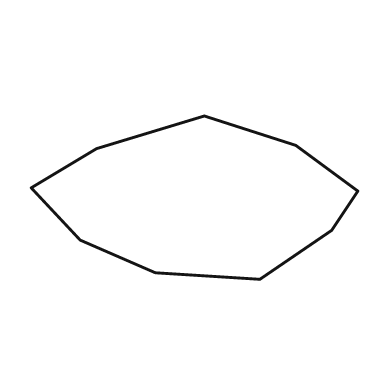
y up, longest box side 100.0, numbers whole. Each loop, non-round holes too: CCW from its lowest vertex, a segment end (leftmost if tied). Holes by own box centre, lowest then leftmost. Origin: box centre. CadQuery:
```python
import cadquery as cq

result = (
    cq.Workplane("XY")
    .moveTo(20.0, -25.0)
    .lineTo(42.0, -10.0)
    .lineTo(50.0, 2.0)
    .lineTo(31.0, 16.0)
    .lineTo(3.0, 25.0)
    .lineTo(-30.0, 15.0)
    .lineTo(-50.0, 3.0)
    .lineTo(-35.0, -13.0)
    .lineTo(-12.0, -23.0)
    .close()
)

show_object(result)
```